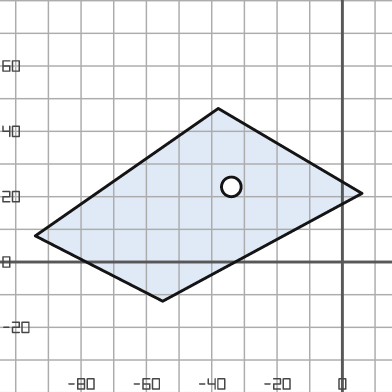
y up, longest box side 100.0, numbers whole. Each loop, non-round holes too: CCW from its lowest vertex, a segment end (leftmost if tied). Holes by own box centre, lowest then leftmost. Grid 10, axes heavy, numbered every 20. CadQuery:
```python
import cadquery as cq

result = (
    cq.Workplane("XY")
    .moveTo(-55.0, -12.0)
    .lineTo(6.0, 21.0)
    .lineTo(-38.0, 47.0)
    .lineTo(-94.0, 8.0)
    .close()
    .moveTo(-34.0, 23.0)
    .circle(3.0)
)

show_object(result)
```